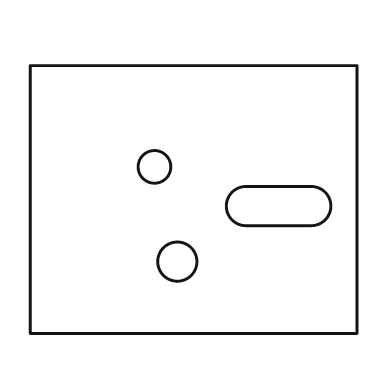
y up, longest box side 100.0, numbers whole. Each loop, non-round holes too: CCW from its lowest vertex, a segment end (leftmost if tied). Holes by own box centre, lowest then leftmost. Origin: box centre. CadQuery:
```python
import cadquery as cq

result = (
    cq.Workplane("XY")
    .moveTo(-50.0, -41.0)
    .lineTo(50.0, -41.0)
    .lineTo(50.0, 41.0)
    .lineTo(-50.0, 41.0)
    .close()
    .moveTo(-5.0, -19.0)
    .circle(6.0)
    .moveTo(16.0, -8.0)
    .lineTo(36.0, -8.0)
    .threePointArc((42.0, -2.0), (36.0, 4.0))
    .lineTo(16.0, 4.0)
    .threePointArc((10.0, -2.0), (16.0, -8.0))
    .close()
    .moveTo(-12.0, 10.0)
    .circle(5.0)
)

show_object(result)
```